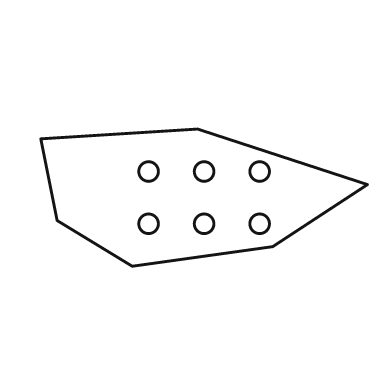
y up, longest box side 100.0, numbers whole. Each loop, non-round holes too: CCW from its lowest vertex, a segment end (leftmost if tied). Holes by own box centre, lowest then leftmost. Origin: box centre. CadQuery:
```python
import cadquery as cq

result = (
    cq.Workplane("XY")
    .moveTo(-22.0, -21.0)
    .lineTo(21.0, -15.0)
    .lineTo(50.0, 4.0)
    .lineTo(-2.0, 21.0)
    .lineTo(-50.0, 18.0)
    .lineTo(-45.0, -7.0)
    .close()
    .moveTo(-17.0, -8.0)
    .circle(3.0)
    .moveTo(0.0, -8.0)
    .circle(3.0)
    .moveTo(17.0, -8.0)
    .circle(3.0)
    .moveTo(-17.0, 8.0)
    .circle(3.0)
    .moveTo(0.0, 8.0)
    .circle(3.0)
    .moveTo(17.0, 8.0)
    .circle(3.0)
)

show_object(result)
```